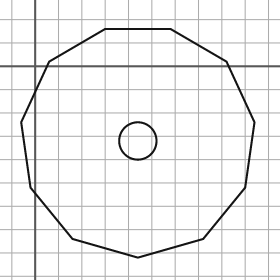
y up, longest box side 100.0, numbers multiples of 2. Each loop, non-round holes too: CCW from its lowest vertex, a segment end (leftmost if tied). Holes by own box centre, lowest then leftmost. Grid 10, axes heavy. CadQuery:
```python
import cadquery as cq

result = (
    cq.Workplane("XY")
    .moveTo(44.0, -82.0)
    .lineTo(72.0, -74.0)
    .lineTo(90.0, -52.0)
    .lineTo(94.0, -24.0)
    .lineTo(82.0, 2.0)
    .lineTo(58.0, 16.0)
    .lineTo(30.0, 16.0)
    .lineTo(6.0, 2.0)
    .lineTo(-6.0, -24.0)
    .lineTo(-2.0, -52.0)
    .lineTo(16.0, -74.0)
    .close()
    .moveTo(44.0, -32.0)
    .circle(8.0)
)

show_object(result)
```